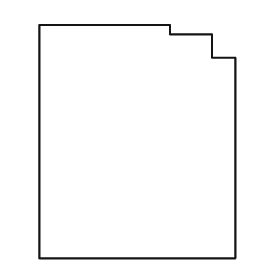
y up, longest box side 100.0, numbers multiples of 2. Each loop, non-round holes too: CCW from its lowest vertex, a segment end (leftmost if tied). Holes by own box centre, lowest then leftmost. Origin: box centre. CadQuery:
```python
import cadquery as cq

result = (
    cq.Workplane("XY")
    .moveTo(-42.0, -50.0)
    .lineTo(42.0, -50.0)
    .lineTo(42.0, 36.0)
    .lineTo(32.0, 36.0)
    .lineTo(32.0, 46.0)
    .lineTo(14.0, 46.0)
    .lineTo(14.0, 50.0)
    .lineTo(-42.0, 50.0)
    .close()
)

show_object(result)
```